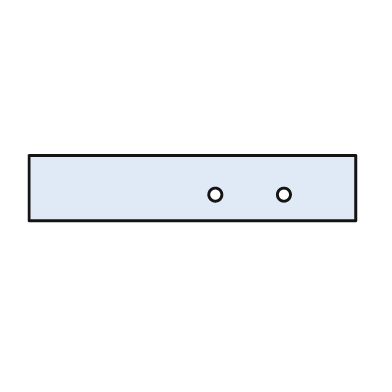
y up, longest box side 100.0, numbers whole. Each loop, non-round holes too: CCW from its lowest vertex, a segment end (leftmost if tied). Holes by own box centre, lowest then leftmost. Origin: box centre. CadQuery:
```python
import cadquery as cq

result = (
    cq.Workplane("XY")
    .moveTo(-50.0, -10.0)
    .lineTo(50.0, -10.0)
    .lineTo(50.0, 10.0)
    .lineTo(-50.0, 10.0)
    .close()
    .moveTo(7.0, -2.0)
    .circle(2.0)
    .moveTo(28.0, -2.0)
    .circle(2.0)
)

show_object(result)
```